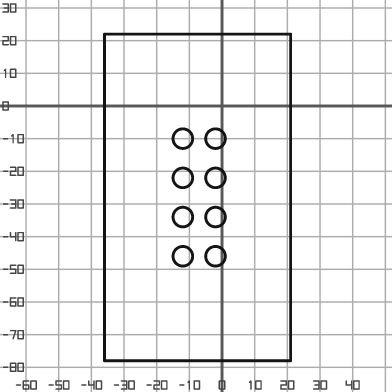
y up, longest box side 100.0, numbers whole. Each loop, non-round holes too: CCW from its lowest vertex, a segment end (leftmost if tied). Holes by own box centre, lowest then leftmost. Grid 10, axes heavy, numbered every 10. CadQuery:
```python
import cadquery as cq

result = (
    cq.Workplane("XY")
    .moveTo(-36.0, -78.0)
    .lineTo(21.0, -78.0)
    .lineTo(21.0, 22.0)
    .lineTo(-36.0, 22.0)
    .close()
    .moveTo(-12.0, -46.0)
    .circle(3.0)
    .moveTo(-2.0, -46.0)
    .circle(3.0)
    .moveTo(-12.0, -34.0)
    .circle(3.0)
    .moveTo(-2.0, -34.0)
    .circle(3.0)
    .moveTo(-12.0, -22.0)
    .circle(3.0)
    .moveTo(-2.0, -22.0)
    .circle(3.0)
    .moveTo(-12.0, -10.0)
    .circle(3.0)
    .moveTo(-2.0, -10.0)
    .circle(3.0)
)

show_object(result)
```